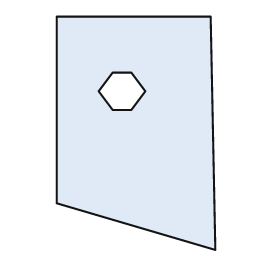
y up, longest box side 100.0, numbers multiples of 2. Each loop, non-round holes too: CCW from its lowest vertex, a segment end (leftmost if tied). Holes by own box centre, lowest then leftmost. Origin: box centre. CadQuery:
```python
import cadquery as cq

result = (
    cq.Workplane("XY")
    .moveTo(34.0, -50.0)
    .lineTo(32.0, 50.0)
    .lineTo(-34.0, 50.0)
    .lineTo(-34.0, -30.0)
    .close()
    .moveTo(-10.0, 10.0)
    .lineTo(-2.0, 10.0)
    .lineTo(4.0, 18.0)
    .lineTo(-2.0, 26.0)
    .lineTo(-10.0, 26.0)
    .lineTo(-16.0, 18.0)
    .close()
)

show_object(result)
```